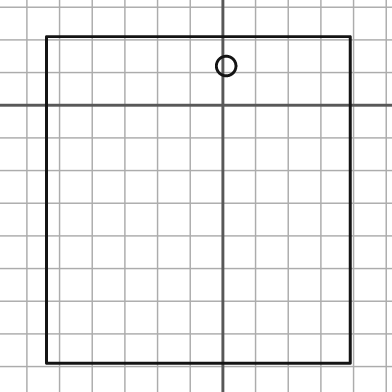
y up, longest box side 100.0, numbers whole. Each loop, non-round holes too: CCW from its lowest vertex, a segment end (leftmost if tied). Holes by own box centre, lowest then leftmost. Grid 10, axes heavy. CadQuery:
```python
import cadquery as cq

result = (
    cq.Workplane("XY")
    .moveTo(-54.0, -79.0)
    .lineTo(39.0, -79.0)
    .lineTo(39.0, 21.0)
    .lineTo(-54.0, 21.0)
    .close()
    .moveTo(1.0, 12.0)
    .circle(3.0)
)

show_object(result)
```